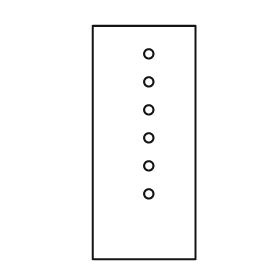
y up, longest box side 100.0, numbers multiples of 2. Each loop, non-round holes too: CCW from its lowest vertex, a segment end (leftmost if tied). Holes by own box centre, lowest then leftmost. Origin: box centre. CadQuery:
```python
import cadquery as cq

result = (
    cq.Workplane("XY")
    .moveTo(-22.0, -50.0)
    .lineTo(22.0, -50.0)
    .lineTo(22.0, 50.0)
    .lineTo(-22.0, 50.0)
    .close()
    .moveTo(2.0, -22.0)
    .circle(2.0)
    .moveTo(2.0, -10.0)
    .circle(2.0)
    .moveTo(2.0, 2.0)
    .circle(2.0)
    .moveTo(2.0, 14.0)
    .circle(2.0)
    .moveTo(2.0, 26.0)
    .circle(2.0)
    .moveTo(2.0, 38.0)
    .circle(2.0)
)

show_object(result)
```